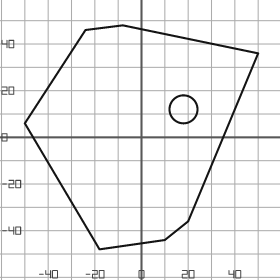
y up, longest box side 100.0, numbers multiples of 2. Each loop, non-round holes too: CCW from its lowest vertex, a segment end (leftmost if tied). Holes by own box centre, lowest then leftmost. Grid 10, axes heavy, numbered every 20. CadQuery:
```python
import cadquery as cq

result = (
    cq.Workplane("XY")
    .moveTo(-18.0, -48.0)
    .lineTo(10.0, -44.0)
    .lineTo(20.0, -36.0)
    .lineTo(50.0, 36.0)
    .lineTo(-8.0, 48.0)
    .lineTo(-24.0, 46.0)
    .lineTo(-50.0, 6.0)
    .close()
    .moveTo(18.0, 12.0)
    .circle(6.0)
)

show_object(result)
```